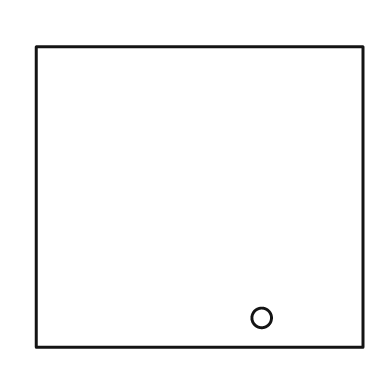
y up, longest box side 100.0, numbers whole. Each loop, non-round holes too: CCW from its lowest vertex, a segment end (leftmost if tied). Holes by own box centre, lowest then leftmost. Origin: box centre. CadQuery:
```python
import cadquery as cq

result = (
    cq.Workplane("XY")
    .moveTo(-50.0, -46.0)
    .lineTo(50.0, -46.0)
    .lineTo(50.0, 46.0)
    .lineTo(-50.0, 46.0)
    .close()
    .moveTo(19.0, -37.0)
    .circle(3.0)
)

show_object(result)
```